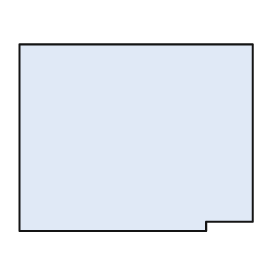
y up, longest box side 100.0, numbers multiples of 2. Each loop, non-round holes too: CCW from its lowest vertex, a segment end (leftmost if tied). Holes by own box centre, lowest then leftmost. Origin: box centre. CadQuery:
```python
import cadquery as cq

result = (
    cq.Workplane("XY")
    .moveTo(-50.0, -40.0)
    .lineTo(30.0, -40.0)
    .lineTo(30.0, -36.0)
    .lineTo(50.0, -36.0)
    .lineTo(50.0, 40.0)
    .lineTo(-50.0, 40.0)
    .close()
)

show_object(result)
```